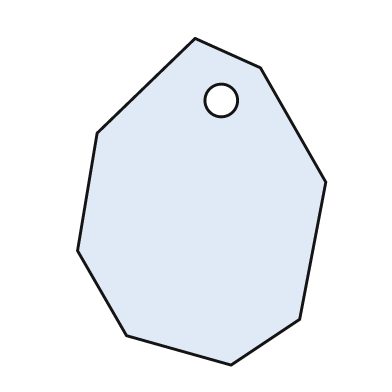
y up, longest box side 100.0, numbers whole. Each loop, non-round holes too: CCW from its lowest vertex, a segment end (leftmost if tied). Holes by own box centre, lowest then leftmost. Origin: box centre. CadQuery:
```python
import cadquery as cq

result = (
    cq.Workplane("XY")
    .moveTo(9.0, -50.0)
    .lineTo(30.0, -36.0)
    .lineTo(38.0, 6.0)
    .lineTo(18.0, 41.0)
    .lineTo(-2.0, 50.0)
    .lineTo(-32.0, 21.0)
    .lineTo(-38.0, -15.0)
    .lineTo(-23.0, -41.0)
    .close()
    .moveTo(6.0, 31.0)
    .circle(5.0)
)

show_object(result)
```